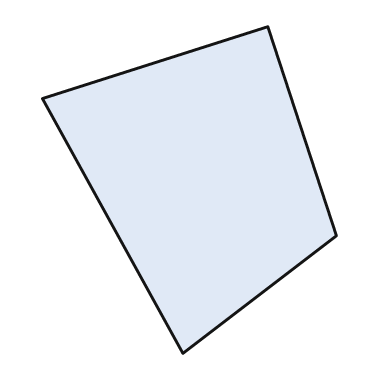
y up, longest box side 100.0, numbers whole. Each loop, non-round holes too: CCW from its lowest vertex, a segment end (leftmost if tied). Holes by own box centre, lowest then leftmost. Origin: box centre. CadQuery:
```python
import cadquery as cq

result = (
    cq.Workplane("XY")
    .moveTo(-2.0, -50.0)
    .lineTo(45.0, -14.0)
    .lineTo(24.0, 50.0)
    .lineTo(-45.0, 28.0)
    .close()
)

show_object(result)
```